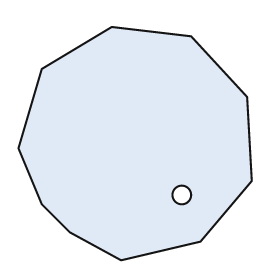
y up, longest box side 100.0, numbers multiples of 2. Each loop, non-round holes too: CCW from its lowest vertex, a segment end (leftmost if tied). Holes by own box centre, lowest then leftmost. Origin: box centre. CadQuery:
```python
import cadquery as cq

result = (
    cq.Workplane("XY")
    .moveTo(-6.0, -50.0)
    .lineTo(28.0, -42.0)
    .lineTo(50.0, -16.0)
    .lineTo(48.0, 20.0)
    .lineTo(24.0, 46.0)
    .lineTo(-10.0, 50.0)
    .lineTo(-40.0, 32.0)
    .lineTo(-50.0, -2.0)
    .lineTo(-40.0, -26.0)
    .lineTo(-28.0, -38.0)
    .close()
    .moveTo(20.0, -22.0)
    .circle(4.0)
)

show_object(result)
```